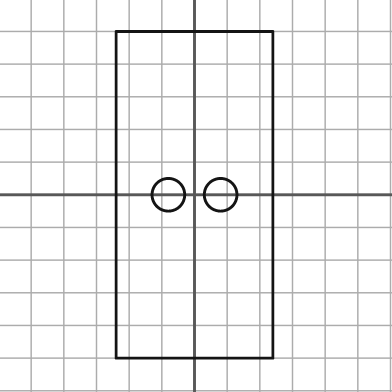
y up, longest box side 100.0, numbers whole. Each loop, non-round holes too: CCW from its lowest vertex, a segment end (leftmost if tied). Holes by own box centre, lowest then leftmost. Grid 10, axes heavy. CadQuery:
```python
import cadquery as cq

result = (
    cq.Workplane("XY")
    .moveTo(-24.0, -50.0)
    .lineTo(24.0, -50.0)
    .lineTo(24.0, 50.0)
    .lineTo(-24.0, 50.0)
    .close()
    .moveTo(-8.0, 0.0)
    .circle(5.0)
    .moveTo(8.0, 0.0)
    .circle(5.0)
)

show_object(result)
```